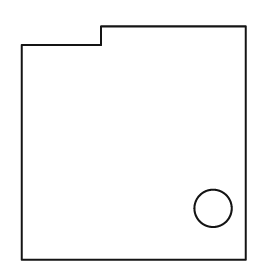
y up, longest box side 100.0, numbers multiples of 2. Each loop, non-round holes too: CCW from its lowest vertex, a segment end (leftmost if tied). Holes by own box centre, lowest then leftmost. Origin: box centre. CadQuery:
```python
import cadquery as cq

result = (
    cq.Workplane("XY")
    .moveTo(-48.0, -50.0)
    .lineTo(48.0, -50.0)
    .lineTo(48.0, 50.0)
    .lineTo(-14.0, 50.0)
    .lineTo(-14.0, 42.0)
    .lineTo(-48.0, 42.0)
    .close()
    .moveTo(34.0, -28.0)
    .circle(8.0)
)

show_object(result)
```